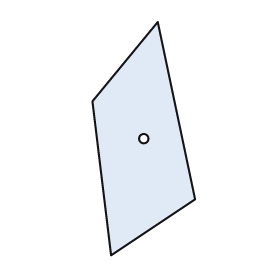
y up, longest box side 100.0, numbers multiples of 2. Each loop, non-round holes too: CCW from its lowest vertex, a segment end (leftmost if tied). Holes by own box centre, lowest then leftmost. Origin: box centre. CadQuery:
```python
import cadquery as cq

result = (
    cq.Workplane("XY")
    .moveTo(-14.0, -50.0)
    .lineTo(22.0, -26.0)
    .lineTo(6.0, 50.0)
    .lineTo(-22.0, 16.0)
    .close()
    .moveTo(0.0, 0.0)
    .circle(2.0)
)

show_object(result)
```